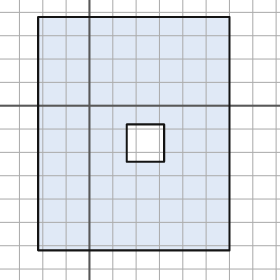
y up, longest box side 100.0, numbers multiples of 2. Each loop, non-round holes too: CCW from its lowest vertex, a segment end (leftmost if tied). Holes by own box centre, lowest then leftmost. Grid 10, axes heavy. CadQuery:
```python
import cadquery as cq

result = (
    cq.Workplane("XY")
    .moveTo(-22.0, -62.0)
    .lineTo(60.0, -62.0)
    .lineTo(60.0, 38.0)
    .lineTo(-22.0, 38.0)
    .close()
    .moveTo(16.0, -24.0)
    .lineTo(32.0, -24.0)
    .lineTo(32.0, -8.0)
    .lineTo(16.0, -8.0)
    .close()
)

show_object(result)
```